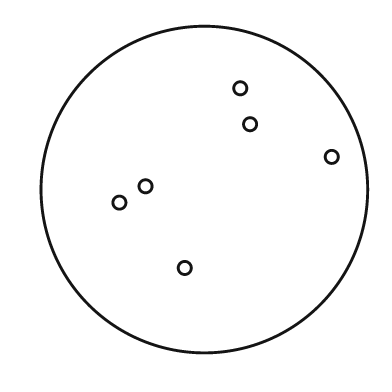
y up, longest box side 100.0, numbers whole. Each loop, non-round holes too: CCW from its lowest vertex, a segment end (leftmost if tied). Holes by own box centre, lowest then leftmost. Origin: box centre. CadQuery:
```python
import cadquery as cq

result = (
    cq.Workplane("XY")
    .moveTo(0.0, 0.0)
    .circle(50.0)
    .moveTo(-6.0, -24.0)
    .circle(2.0)
    .moveTo(-26.0, -4.0)
    .circle(2.0)
    .moveTo(-18.0, 1.0)
    .circle(2.0)
    .moveTo(39.0, 10.0)
    .circle(2.0)
    .moveTo(14.0, 20.0)
    .circle(2.0)
    .moveTo(11.0, 31.0)
    .circle(2.0)
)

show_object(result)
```